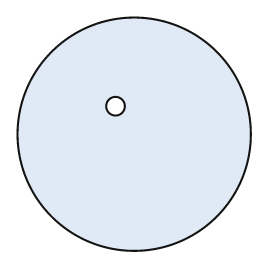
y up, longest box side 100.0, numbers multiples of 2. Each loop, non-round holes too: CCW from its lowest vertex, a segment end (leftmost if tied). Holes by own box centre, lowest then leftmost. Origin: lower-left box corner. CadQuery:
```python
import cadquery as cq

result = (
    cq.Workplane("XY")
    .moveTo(50.0, 50.0)
    .circle(50.0)
    .moveTo(42.0, 62.0)
    .circle(4.0)
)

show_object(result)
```